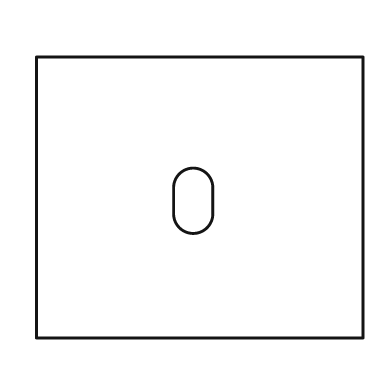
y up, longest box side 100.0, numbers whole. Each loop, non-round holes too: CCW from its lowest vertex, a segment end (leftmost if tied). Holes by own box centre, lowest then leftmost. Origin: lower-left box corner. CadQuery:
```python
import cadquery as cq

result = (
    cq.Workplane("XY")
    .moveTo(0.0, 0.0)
    .lineTo(100.0, 0.0)
    .lineTo(100.0, 86.0)
    .lineTo(0.0, 86.0)
    .close()
    .moveTo(42.0, 38.0)
    .threePointArc((48.0, 32.0), (54.0, 38.0))
    .lineTo(54.0, 46.0)
    .threePointArc((48.0, 52.0), (42.0, 46.0))
    .close()
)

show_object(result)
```